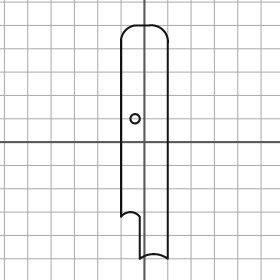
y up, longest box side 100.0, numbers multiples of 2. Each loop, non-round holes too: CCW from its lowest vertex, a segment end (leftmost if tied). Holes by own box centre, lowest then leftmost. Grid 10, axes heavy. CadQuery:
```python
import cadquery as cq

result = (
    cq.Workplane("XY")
    .moveTo(-2.0, -50.0)
    .threePointArc((4.0, -48.0), (10.0, -50.0))
    .lineTo(10.0, 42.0)
    .threePointArc((8.0, 48.0), (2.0, 50.0))
    .lineTo(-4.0, 50.0)
    .threePointArc((-8.0, 48.0), (-10.0, 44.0))
    .lineTo(-10.0, -32.0)
    .threePointArc((-6.0, -30.0), (-2.0, -32.0))
    .close()
    .moveTo(-4.0, 10.0)
    .circle(2.0)
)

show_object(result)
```